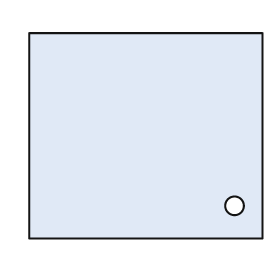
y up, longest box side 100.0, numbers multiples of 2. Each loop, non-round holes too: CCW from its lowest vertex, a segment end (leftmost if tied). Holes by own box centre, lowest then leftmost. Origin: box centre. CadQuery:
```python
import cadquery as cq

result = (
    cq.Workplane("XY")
    .moveTo(-50.0, -44.0)
    .lineTo(50.0, -44.0)
    .lineTo(50.0, 44.0)
    .lineTo(-50.0, 44.0)
    .close()
    .moveTo(38.0, -30.0)
    .circle(4.0)
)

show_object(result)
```